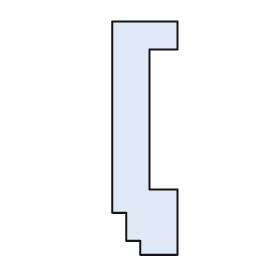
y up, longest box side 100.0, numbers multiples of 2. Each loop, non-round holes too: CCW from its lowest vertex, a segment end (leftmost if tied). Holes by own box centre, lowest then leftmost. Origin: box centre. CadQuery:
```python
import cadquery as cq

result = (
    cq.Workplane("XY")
    .moveTo(-2.0, -50.0)
    .lineTo(14.0, -50.0)
    .lineTo(14.0, -22.0)
    .lineTo(2.0, -22.0)
    .lineTo(2.0, 38.0)
    .lineTo(14.0, 38.0)
    .lineTo(14.0, 50.0)
    .lineTo(-14.0, 50.0)
    .lineTo(-14.0, -32.0)
    .lineTo(-8.0, -32.0)
    .lineTo(-8.0, -44.0)
    .lineTo(-2.0, -44.0)
    .close()
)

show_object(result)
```